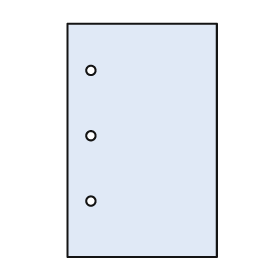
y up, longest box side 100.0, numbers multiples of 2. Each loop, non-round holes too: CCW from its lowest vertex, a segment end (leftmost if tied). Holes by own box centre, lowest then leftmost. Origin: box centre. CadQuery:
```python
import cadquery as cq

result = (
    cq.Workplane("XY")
    .moveTo(-32.0, -50.0)
    .lineTo(32.0, -50.0)
    .lineTo(32.0, 50.0)
    .lineTo(-32.0, 50.0)
    .close()
    .moveTo(-22.0, -26.0)
    .circle(2.0)
    .moveTo(-22.0, 2.0)
    .circle(2.0)
    .moveTo(-22.0, 30.0)
    .circle(2.0)
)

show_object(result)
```